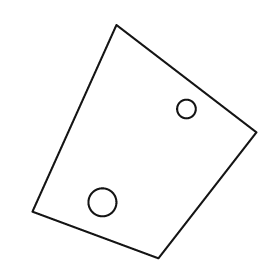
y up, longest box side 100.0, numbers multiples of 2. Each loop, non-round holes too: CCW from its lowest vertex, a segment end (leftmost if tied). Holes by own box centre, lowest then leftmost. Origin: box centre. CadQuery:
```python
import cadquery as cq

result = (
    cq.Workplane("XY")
    .moveTo(6.0, -50.0)
    .lineTo(48.0, 4.0)
    .lineTo(-12.0, 50.0)
    .lineTo(-48.0, -30.0)
    .close()
    .moveTo(-18.0, -26.0)
    .circle(6.0)
    .moveTo(18.0, 14.0)
    .circle(4.0)
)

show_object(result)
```